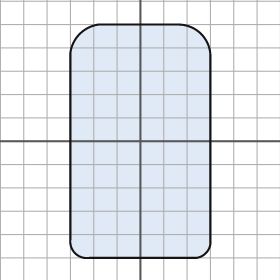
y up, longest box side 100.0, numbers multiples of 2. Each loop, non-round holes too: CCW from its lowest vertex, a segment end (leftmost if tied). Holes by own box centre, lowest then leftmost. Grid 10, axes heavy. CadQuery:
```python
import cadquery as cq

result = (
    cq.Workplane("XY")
    .moveTo(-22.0, -50.0)
    .lineTo(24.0, -50.0)
    .threePointArc((28.0, -48.0), (30.0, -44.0))
    .lineTo(30.0, 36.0)
    .threePointArc((26.0, 46.0), (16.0, 50.0))
    .lineTo(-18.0, 50.0)
    .threePointArc((-26.0, 46.0), (-30.0, 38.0))
    .lineTo(-30.0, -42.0)
    .threePointArc((-28.0, -48.0), (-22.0, -50.0))
    .close()
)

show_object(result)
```